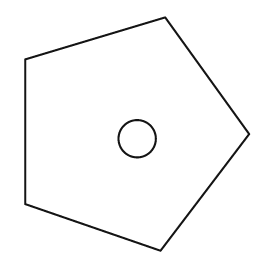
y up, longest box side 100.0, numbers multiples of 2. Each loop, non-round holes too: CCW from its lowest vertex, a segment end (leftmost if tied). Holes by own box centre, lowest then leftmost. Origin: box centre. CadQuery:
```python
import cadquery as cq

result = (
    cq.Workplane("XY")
    .moveTo(10.0, -50.0)
    .lineTo(48.0, 0.0)
    .lineTo(12.0, 50.0)
    .lineTo(-48.0, 32.0)
    .lineTo(-48.0, -30.0)
    .close()
    .moveTo(0.0, -2.0)
    .circle(8.0)
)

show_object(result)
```